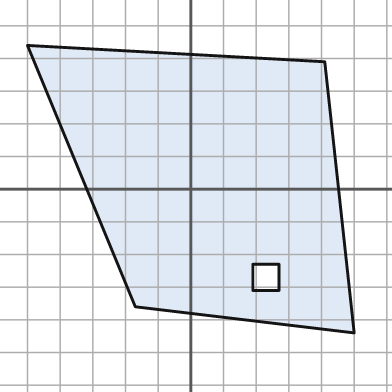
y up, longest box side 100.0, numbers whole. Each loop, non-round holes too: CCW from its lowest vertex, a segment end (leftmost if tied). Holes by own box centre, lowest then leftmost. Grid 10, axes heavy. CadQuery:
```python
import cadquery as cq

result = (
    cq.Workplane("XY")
    .moveTo(50.0, -44.0)
    .lineTo(41.0, 39.0)
    .lineTo(-50.0, 44.0)
    .lineTo(-17.0, -36.0)
    .close()
    .moveTo(19.0, -31.0)
    .lineTo(27.0, -31.0)
    .lineTo(27.0, -23.0)
    .lineTo(19.0, -23.0)
    .close()
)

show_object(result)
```